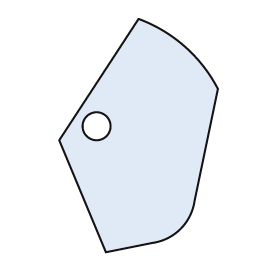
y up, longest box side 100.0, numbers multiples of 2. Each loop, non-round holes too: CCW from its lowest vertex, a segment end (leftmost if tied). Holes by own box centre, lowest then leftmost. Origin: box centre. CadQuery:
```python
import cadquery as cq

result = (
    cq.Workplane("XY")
    .moveTo(-14.0, -50.0)
    .lineTo(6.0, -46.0)
    .threePointArc((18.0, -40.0), (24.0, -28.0))
    .lineTo(34.0, 20.0)
    .threePointArc((20.0, 38.0), (0.0, 50.0))
    .lineTo(-34.0, -2.0)
    .close()
    .moveTo(-18.0, 4.0)
    .circle(6.0)
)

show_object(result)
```